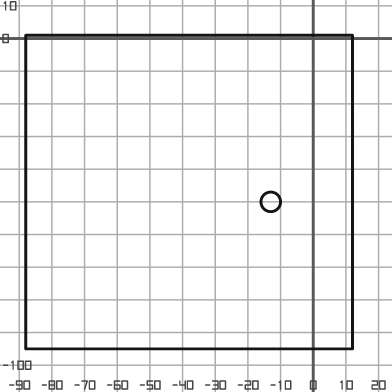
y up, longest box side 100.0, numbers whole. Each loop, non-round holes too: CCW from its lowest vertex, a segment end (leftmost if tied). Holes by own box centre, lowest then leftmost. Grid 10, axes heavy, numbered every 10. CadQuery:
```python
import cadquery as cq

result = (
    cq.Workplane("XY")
    .moveTo(-88.0, -95.0)
    .lineTo(12.0, -95.0)
    .lineTo(12.0, 1.0)
    .lineTo(-88.0, 1.0)
    .close()
    .moveTo(-13.0, -50.0)
    .circle(3.0)
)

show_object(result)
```